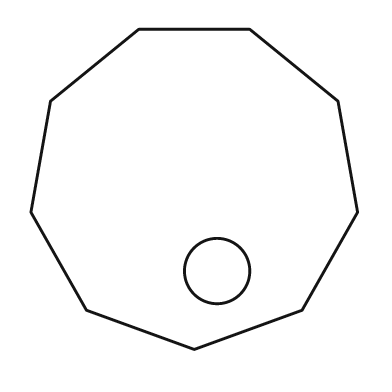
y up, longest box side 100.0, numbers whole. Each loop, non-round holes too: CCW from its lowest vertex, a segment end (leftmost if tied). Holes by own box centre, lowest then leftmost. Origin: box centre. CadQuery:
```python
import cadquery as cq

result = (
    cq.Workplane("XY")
    .moveTo(0.0, -49.0)
    .lineTo(33.0, -37.0)
    .lineTo(50.0, -7.0)
    .lineTo(44.0, 27.0)
    .lineTo(17.0, 49.0)
    .lineTo(-17.0, 49.0)
    .lineTo(-44.0, 27.0)
    .lineTo(-50.0, -7.0)
    .lineTo(-33.0, -37.0)
    .close()
    .moveTo(7.0, -25.0)
    .circle(10.0)
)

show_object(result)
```